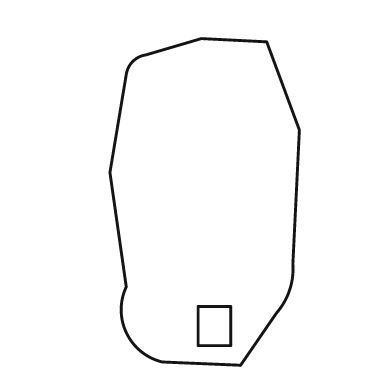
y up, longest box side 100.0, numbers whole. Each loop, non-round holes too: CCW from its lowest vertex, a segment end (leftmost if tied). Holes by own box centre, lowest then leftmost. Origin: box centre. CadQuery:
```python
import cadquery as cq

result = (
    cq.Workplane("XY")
    .moveTo(11.0, -50.0)
    .lineTo(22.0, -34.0)
    .threePointArc((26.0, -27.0), (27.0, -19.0))
    .lineTo(29.0, 22.0)
    .lineTo(19.0, 49.0)
    .lineTo(-1.0, 50.0)
    .lineTo(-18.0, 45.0)
    .threePointArc((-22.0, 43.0), (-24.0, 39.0))
    .lineTo(-29.0, 9.0)
    .lineTo(-24.0, -26.0)
    .threePointArc((-24.0, -40.0), (-13.0, -49.0))
    .close()
    .moveTo(-2.0, -44.0)
    .lineTo(8.0, -44.0)
    .lineTo(8.0, -32.0)
    .lineTo(-2.0, -32.0)
    .close()
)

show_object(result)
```